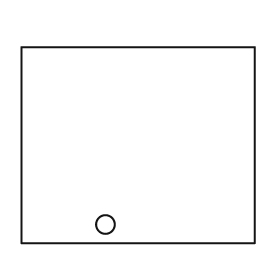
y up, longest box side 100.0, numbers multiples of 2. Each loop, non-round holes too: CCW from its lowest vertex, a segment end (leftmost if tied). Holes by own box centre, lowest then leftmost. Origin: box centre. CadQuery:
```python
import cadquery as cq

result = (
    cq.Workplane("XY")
    .moveTo(-50.0, -42.0)
    .lineTo(50.0, -42.0)
    .lineTo(50.0, 42.0)
    .lineTo(-50.0, 42.0)
    .close()
    .moveTo(-14.0, -34.0)
    .circle(4.0)
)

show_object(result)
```